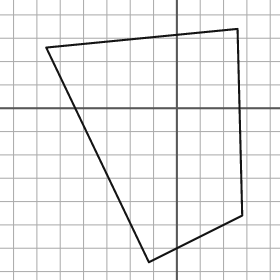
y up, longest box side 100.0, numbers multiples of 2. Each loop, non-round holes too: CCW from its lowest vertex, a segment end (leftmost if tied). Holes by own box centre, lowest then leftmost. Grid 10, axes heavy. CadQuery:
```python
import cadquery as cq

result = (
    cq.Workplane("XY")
    .moveTo(-12.0, -66.0)
    .lineTo(28.0, -46.0)
    .lineTo(26.0, 34.0)
    .lineTo(-56.0, 26.0)
    .close()
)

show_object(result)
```